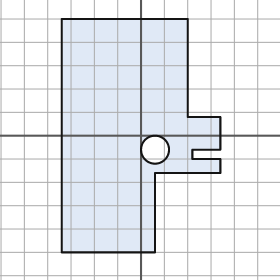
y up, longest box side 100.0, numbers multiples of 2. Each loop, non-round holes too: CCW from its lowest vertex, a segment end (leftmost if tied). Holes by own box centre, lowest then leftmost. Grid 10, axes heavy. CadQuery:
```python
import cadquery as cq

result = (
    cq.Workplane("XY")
    .moveTo(-34.0, -50.0)
    .lineTo(6.0, -50.0)
    .lineTo(6.0, -16.0)
    .lineTo(34.0, -16.0)
    .lineTo(34.0, -10.0)
    .lineTo(22.0, -10.0)
    .lineTo(22.0, -6.0)
    .lineTo(34.0, -6.0)
    .lineTo(34.0, 8.0)
    .lineTo(20.0, 8.0)
    .lineTo(20.0, 50.0)
    .lineTo(-34.0, 50.0)
    .close()
    .moveTo(6.0, -6.0)
    .circle(6.0)
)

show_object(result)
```